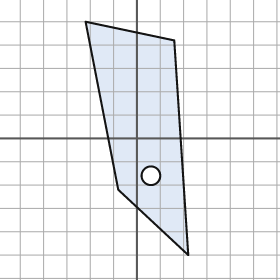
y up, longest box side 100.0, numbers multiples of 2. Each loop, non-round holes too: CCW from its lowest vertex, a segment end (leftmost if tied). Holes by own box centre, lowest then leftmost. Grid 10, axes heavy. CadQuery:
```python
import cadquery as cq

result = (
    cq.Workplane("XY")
    .moveTo(22.0, -50.0)
    .lineTo(16.0, 42.0)
    .lineTo(-22.0, 50.0)
    .lineTo(-8.0, -22.0)
    .close()
    .moveTo(6.0, -16.0)
    .circle(4.0)
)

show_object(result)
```